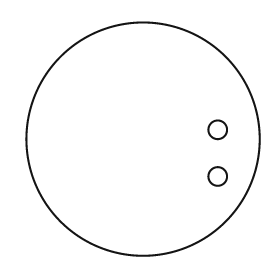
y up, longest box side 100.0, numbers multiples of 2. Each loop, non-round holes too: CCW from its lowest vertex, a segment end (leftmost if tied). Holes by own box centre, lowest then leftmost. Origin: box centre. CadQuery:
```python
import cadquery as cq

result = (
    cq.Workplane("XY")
    .moveTo(0.0, 0.0)
    .circle(50.0)
    .moveTo(32.0, -16.0)
    .circle(4.0)
    .moveTo(32.0, 4.0)
    .circle(4.0)
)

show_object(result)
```